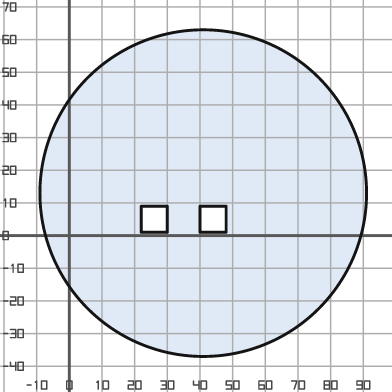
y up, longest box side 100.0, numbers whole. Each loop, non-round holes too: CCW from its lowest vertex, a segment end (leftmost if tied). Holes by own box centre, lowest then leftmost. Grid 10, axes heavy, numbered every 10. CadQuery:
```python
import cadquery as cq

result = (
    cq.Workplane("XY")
    .moveTo(41.0, 13.0)
    .circle(50.0)
    .moveTo(22.0, 1.0)
    .lineTo(30.0, 1.0)
    .lineTo(30.0, 9.0)
    .lineTo(22.0, 9.0)
    .close()
    .moveTo(40.0, 1.0)
    .lineTo(48.0, 1.0)
    .lineTo(48.0, 9.0)
    .lineTo(40.0, 9.0)
    .close()
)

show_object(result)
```